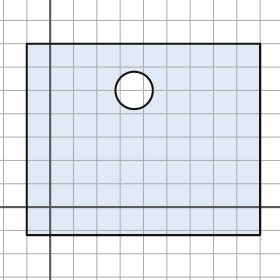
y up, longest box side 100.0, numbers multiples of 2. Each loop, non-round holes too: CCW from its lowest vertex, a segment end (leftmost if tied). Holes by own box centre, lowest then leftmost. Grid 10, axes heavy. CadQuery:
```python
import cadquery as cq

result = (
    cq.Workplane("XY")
    .moveTo(-10.0, -12.0)
    .lineTo(90.0, -12.0)
    .lineTo(90.0, 70.0)
    .lineTo(-10.0, 70.0)
    .close()
    .moveTo(36.0, 50.0)
    .circle(8.0)
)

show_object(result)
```